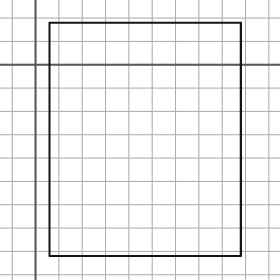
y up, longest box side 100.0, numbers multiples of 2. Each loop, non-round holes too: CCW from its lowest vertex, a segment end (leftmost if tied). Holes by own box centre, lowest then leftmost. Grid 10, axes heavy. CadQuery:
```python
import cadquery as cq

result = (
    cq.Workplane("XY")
    .moveTo(6.0, -82.0)
    .lineTo(88.0, -82.0)
    .lineTo(88.0, 18.0)
    .lineTo(6.0, 18.0)
    .close()
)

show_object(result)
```